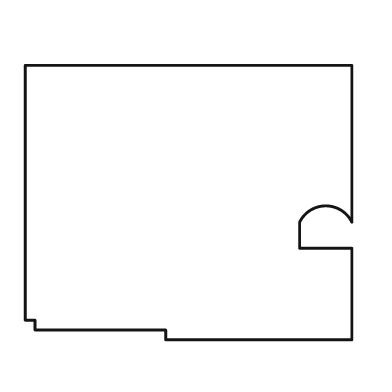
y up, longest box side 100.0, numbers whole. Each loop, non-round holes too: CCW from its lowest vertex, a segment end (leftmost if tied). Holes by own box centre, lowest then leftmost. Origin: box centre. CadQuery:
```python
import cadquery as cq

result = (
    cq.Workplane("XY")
    .moveTo(-7.0, -42.0)
    .lineTo(50.0, -42.0)
    .lineTo(50.0, -14.0)
    .lineTo(34.0, -14.0)
    .lineTo(34.0, -6.0)
    .threePointArc((42.0, -1.0), (50.0, -6.0))
    .lineTo(50.0, 42.0)
    .lineTo(-50.0, 42.0)
    .lineTo(-50.0, -36.0)
    .lineTo(-47.0, -36.0)
    .lineTo(-47.0, -39.0)
    .lineTo(-7.0, -39.0)
    .close()
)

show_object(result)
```